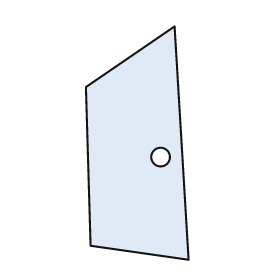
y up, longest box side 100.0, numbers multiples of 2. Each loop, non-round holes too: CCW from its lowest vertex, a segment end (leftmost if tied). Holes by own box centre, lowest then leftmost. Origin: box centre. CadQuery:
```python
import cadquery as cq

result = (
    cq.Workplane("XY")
    .moveTo(22.0, -50.0)
    .lineTo(16.0, 50.0)
    .lineTo(-22.0, 24.0)
    .lineTo(-20.0, -44.0)
    .close()
    .moveTo(10.0, -6.0)
    .circle(4.0)
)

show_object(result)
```